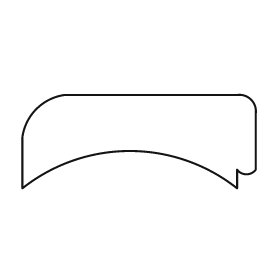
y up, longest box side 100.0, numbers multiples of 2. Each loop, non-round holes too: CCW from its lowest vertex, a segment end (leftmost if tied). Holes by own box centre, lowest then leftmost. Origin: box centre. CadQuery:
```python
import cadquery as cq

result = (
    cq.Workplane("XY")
    .moveTo(-50.0, -20.0)
    .threePointArc((-4.0, -4.0), (42.0, -20.0))
    .lineTo(42.0, -12.0)
    .threePointArc((46.0, -14.0), (50.0, -12.0))
    .lineTo(50.0, 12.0)
    .threePointArc((48.0, 18.0), (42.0, 20.0))
    .lineTo(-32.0, 20.0)
    .threePointArc((-44.0, 14.0), (-50.0, 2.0))
    .close()
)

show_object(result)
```